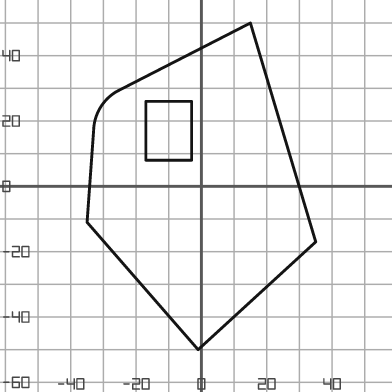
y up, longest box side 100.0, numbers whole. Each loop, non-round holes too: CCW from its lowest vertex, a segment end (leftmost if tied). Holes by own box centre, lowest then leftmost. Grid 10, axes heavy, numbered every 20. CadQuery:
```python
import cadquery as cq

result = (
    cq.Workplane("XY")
    .moveTo(-1.0, -50.0)
    .lineTo(35.0, -17.0)
    .lineTo(15.0, 50.0)
    .lineTo(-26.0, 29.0)
    .threePointArc((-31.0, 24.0), (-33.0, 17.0))
    .lineTo(-35.0, -11.0)
    .close()
    .moveTo(-17.0, 8.0)
    .lineTo(-3.0, 8.0)
    .lineTo(-3.0, 26.0)
    .lineTo(-17.0, 26.0)
    .close()
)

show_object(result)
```